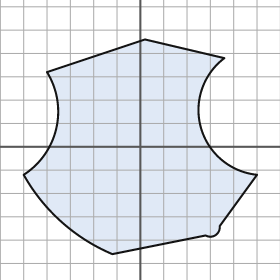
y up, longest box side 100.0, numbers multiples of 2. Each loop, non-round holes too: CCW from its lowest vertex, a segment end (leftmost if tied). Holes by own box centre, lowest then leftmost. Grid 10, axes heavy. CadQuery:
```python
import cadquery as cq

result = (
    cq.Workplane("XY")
    .moveTo(-12.0, -46.0)
    .lineTo(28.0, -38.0)
    .threePointArc((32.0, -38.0), (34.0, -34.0))
    .lineTo(50.0, -12.0)
    .threePointArc((26.0, 8.0), (36.0, 38.0))
    .lineTo(2.0, 46.0)
    .lineTo(-40.0, 32.0)
    .threePointArc((-36.0, 8.0), (-50.0, -12.0))
    .threePointArc((-34.0, -32.0), (-12.0, -46.0))
    .close()
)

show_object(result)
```